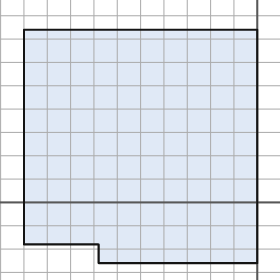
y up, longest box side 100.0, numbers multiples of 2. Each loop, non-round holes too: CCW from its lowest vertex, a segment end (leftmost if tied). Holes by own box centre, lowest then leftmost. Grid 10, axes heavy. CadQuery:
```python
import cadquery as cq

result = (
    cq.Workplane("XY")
    .moveTo(-68.0, -26.0)
    .lineTo(0.0, -26.0)
    .lineTo(0.0, 74.0)
    .lineTo(-100.0, 74.0)
    .lineTo(-100.0, -18.0)
    .lineTo(-68.0, -18.0)
    .close()
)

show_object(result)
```